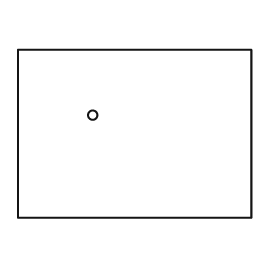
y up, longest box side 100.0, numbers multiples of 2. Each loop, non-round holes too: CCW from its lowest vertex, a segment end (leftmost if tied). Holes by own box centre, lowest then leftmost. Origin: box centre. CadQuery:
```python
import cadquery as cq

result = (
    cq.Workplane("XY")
    .moveTo(-50.0, -36.0)
    .lineTo(50.0, -36.0)
    .lineTo(50.0, 36.0)
    .lineTo(-50.0, 36.0)
    .close()
    .moveTo(-18.0, 8.0)
    .circle(2.0)
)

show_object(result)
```